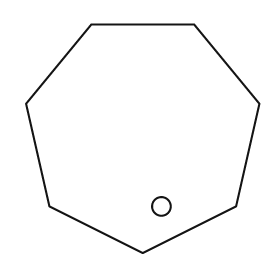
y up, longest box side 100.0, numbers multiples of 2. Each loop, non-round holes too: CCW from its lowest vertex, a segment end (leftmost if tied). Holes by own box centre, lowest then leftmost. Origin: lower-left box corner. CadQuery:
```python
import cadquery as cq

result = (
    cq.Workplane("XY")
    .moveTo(50.0, 0.0)
    .lineTo(90.0, 20.0)
    .lineTo(100.0, 64.0)
    .lineTo(72.0, 98.0)
    .lineTo(28.0, 98.0)
    .lineTo(0.0, 64.0)
    .lineTo(10.0, 20.0)
    .close()
    .moveTo(58.0, 20.0)
    .circle(4.0)
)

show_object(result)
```